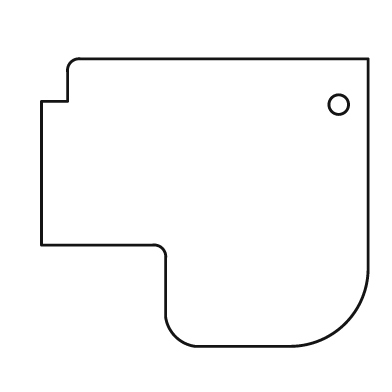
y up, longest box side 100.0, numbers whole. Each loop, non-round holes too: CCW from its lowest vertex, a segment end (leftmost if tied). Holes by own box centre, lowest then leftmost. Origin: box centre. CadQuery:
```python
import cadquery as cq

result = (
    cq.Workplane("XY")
    .moveTo(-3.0, -44.0)
    .lineTo(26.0, -44.0)
    .threePointArc((43.0, -37.0), (50.0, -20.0))
    .lineTo(50.0, 44.0)
    .lineTo(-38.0, 44.0)
    .threePointArc((-41.0, 43.0), (-42.0, 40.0))
    .lineTo(-42.0, 31.0)
    .lineTo(-50.0, 31.0)
    .lineTo(-50.0, -13.0)
    .lineTo(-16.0, -13.0)
    .threePointArc((-13.0, -14.0), (-12.0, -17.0))
    .lineTo(-12.0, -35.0)
    .threePointArc((-9.0, -41.0), (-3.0, -44.0))
    .close()
    .moveTo(41.0, 30.0)
    .circle(3.0)
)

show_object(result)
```